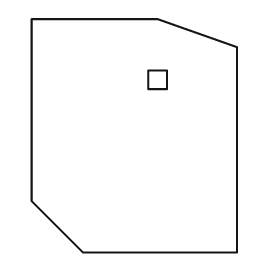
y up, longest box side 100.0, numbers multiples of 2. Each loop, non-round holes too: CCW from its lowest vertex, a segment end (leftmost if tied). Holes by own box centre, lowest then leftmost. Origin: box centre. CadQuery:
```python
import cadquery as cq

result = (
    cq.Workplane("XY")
    .moveTo(-22.0, -50.0)
    .lineTo(44.0, -50.0)
    .lineTo(44.0, 38.0)
    .lineTo(10.0, 50.0)
    .lineTo(-44.0, 50.0)
    .lineTo(-44.0, -28.0)
    .close()
    .moveTo(6.0, 20.0)
    .lineTo(14.0, 20.0)
    .lineTo(14.0, 28.0)
    .lineTo(6.0, 28.0)
    .close()
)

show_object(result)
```